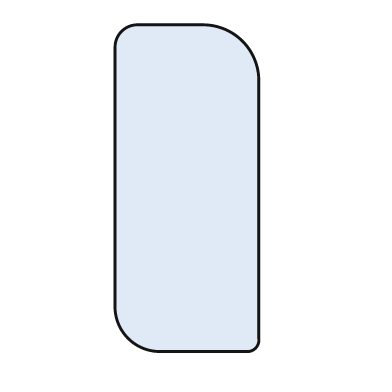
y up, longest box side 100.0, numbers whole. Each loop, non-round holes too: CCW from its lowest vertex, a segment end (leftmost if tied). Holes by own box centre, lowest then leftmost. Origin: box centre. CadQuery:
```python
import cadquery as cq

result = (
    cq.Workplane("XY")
    .moveTo(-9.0, -50.0)
    .lineTo(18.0, -50.0)
    .threePointArc((21.0, -49.0), (22.0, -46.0))
    .lineTo(22.0, 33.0)
    .threePointArc((17.0, 45.0), (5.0, 50.0))
    .lineTo(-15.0, 50.0)
    .threePointArc((-20.0, 48.0), (-22.0, 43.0))
    .lineTo(-22.0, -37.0)
    .threePointArc((-18.0, -46.0), (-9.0, -50.0))
    .close()
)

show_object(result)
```